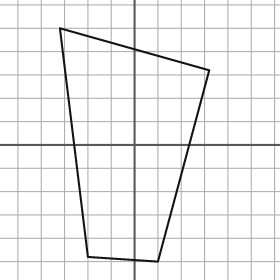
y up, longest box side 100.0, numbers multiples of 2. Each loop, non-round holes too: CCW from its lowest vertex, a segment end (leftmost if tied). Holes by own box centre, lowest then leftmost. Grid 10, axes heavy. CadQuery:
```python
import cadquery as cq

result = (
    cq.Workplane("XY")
    .moveTo(10.0, -50.0)
    .lineTo(32.0, 32.0)
    .lineTo(-32.0, 50.0)
    .lineTo(-20.0, -48.0)
    .close()
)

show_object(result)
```